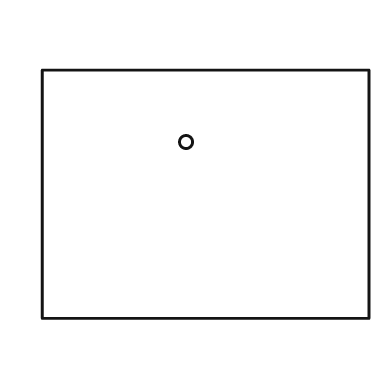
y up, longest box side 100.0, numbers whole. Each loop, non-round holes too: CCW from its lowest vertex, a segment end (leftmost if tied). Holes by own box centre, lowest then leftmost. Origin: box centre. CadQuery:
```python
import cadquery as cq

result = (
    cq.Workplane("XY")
    .moveTo(-50.0, -38.0)
    .lineTo(50.0, -38.0)
    .lineTo(50.0, 38.0)
    .lineTo(-50.0, 38.0)
    .close()
    .moveTo(-6.0, 16.0)
    .circle(2.0)
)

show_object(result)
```